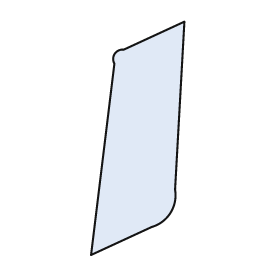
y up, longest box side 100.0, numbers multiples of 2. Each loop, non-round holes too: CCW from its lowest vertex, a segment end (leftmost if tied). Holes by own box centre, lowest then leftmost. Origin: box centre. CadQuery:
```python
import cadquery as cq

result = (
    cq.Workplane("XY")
    .moveTo(-20.0, -50.0)
    .lineTo(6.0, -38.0)
    .threePointArc((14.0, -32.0), (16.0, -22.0))
    .lineTo(20.0, 50.0)
    .lineTo(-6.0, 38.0)
    .threePointArc((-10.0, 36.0), (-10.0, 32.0))
    .close()
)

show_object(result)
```